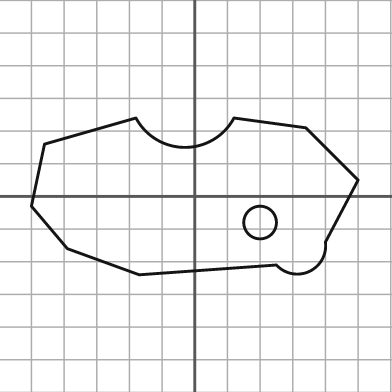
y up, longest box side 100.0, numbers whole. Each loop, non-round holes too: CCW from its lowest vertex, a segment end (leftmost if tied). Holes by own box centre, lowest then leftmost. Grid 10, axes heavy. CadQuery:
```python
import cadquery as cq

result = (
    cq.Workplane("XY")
    .moveTo(-17.0, -24.0)
    .lineTo(25.0, -21.0)
    .threePointArc((35.0, -23.0), (40.0, -14.0))
    .lineTo(50.0, 5.0)
    .lineTo(34.0, 21.0)
    .lineTo(12.0, 24.0)
    .threePointArc((-3.0, 15.0), (-18.0, 24.0))
    .lineTo(-46.0, 16.0)
    .lineTo(-50.0, -3.0)
    .lineTo(-39.0, -16.0)
    .close()
    .moveTo(20.0, -8.0)
    .circle(5.0)
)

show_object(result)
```